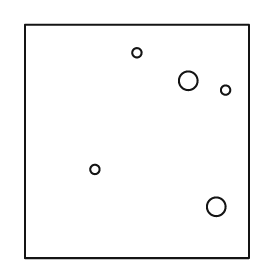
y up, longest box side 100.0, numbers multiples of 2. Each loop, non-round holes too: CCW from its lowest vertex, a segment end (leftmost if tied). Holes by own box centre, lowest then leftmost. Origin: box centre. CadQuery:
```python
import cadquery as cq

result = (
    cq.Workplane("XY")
    .moveTo(-48.0, -50.0)
    .lineTo(48.0, -50.0)
    .lineTo(48.0, 50.0)
    .lineTo(-48.0, 50.0)
    .close()
    .moveTo(34.0, -28.0)
    .circle(4.0)
    .moveTo(-18.0, -12.0)
    .circle(2.0)
    .moveTo(38.0, 22.0)
    .circle(2.0)
    .moveTo(22.0, 26.0)
    .circle(4.0)
    .moveTo(0.0, 38.0)
    .circle(2.0)
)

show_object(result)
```